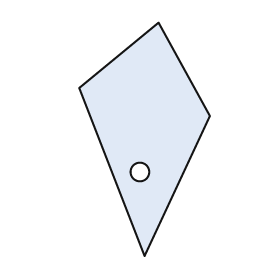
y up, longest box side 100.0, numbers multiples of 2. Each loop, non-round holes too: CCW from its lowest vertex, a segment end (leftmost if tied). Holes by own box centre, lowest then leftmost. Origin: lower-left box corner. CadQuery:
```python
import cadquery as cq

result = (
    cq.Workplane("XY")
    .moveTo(28.0, 0.0)
    .lineTo(56.0, 60.0)
    .lineTo(34.0, 100.0)
    .lineTo(0.0, 72.0)
    .close()
    .moveTo(26.0, 36.0)
    .circle(4.0)
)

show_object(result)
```